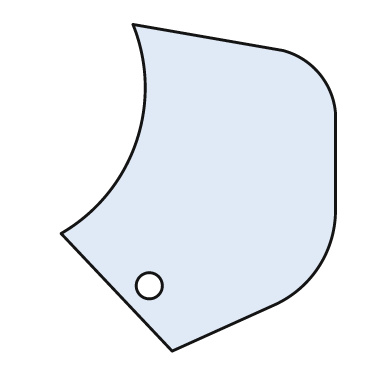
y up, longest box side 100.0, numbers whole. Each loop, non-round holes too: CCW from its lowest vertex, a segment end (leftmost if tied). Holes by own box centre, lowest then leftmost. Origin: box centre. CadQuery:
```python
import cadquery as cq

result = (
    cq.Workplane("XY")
    .moveTo(-8.0, -50.0)
    .lineTo(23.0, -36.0)
    .threePointArc((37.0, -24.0), (42.0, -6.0))
    .lineTo(42.0, 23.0)
    .threePointArc((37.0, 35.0), (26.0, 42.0))
    .lineTo(-20.0, 50.0)
    .threePointArc((-19.0, 14.0), (-42.0, -14.0))
    .close()
    .moveTo(-15.0, -30.0)
    .circle(4.0)
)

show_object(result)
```